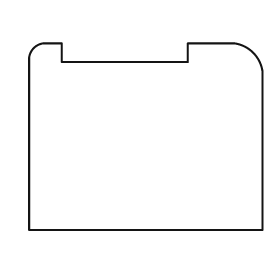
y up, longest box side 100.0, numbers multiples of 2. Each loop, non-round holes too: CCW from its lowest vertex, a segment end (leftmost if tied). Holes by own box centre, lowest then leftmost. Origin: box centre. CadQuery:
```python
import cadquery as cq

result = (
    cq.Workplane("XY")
    .moveTo(-50.0, -40.0)
    .lineTo(50.0, -40.0)
    .lineTo(50.0, 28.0)
    .threePointArc((46.0, 36.0), (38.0, 40.0))
    .lineTo(18.0, 40.0)
    .lineTo(18.0, 32.0)
    .lineTo(-36.0, 32.0)
    .lineTo(-36.0, 40.0)
    .lineTo(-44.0, 40.0)
    .threePointArc((-48.0, 38.0), (-50.0, 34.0))
    .close()
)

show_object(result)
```